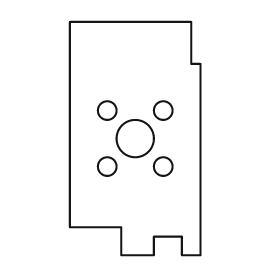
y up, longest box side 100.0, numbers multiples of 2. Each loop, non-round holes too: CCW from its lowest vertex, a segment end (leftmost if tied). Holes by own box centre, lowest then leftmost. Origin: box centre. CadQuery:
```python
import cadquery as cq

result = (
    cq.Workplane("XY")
    .moveTo(-6.0, -50.0)
    .lineTo(8.0, -50.0)
    .lineTo(8.0, -42.0)
    .lineTo(20.0, -42.0)
    .lineTo(20.0, -50.0)
    .lineTo(28.0, -50.0)
    .lineTo(28.0, 32.0)
    .lineTo(24.0, 32.0)
    .lineTo(24.0, 50.0)
    .lineTo(-28.0, 50.0)
    .lineTo(-28.0, -38.0)
    .lineTo(-6.0, -38.0)
    .close()
    .moveTo(-12.0, -12.0)
    .circle(4.0)
    .moveTo(12.0, -12.0)
    .circle(4.0)
    .moveTo(0.0, 0.0)
    .circle(8.0)
    .moveTo(-12.0, 12.0)
    .circle(4.0)
    .moveTo(12.0, 12.0)
    .circle(4.0)
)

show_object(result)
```